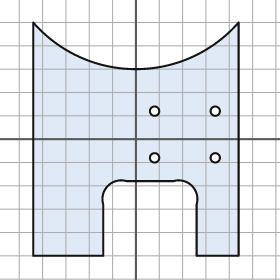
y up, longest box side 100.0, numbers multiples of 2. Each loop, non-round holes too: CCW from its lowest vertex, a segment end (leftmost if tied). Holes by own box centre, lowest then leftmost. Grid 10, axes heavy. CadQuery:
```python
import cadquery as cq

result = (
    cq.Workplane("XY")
    .moveTo(-44.0, -50.0)
    .lineTo(-14.0, -50.0)
    .lineTo(-14.0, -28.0)
    .threePointArc((-12.0, -20.0), (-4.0, -18.0))
    .lineTo(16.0, -18.0)
    .threePointArc((24.0, -20.0), (26.0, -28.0))
    .lineTo(26.0, -50.0)
    .lineTo(44.0, -50.0)
    .lineTo(44.0, 50.0)
    .threePointArc((0.0, 30.0), (-44.0, 50.0))
    .close()
    .moveTo(8.0, -8.0)
    .circle(2.0)
    .moveTo(34.0, -8.0)
    .circle(2.0)
    .moveTo(8.0, 12.0)
    .circle(2.0)
    .moveTo(34.0, 12.0)
    .circle(2.0)
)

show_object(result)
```